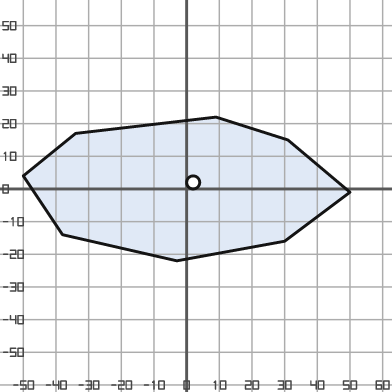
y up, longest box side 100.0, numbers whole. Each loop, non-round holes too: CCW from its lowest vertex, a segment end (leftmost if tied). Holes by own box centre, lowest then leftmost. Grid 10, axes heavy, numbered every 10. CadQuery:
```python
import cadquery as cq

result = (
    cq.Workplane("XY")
    .moveTo(-3.0, -22.0)
    .lineTo(30.0, -16.0)
    .lineTo(50.0, -1.0)
    .lineTo(31.0, 15.0)
    .lineTo(9.0, 22.0)
    .lineTo(-34.0, 17.0)
    .lineTo(-50.0, 4.0)
    .lineTo(-38.0, -14.0)
    .close()
    .moveTo(2.0, 2.0)
    .circle(2.0)
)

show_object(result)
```